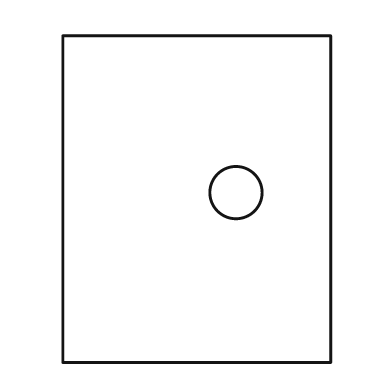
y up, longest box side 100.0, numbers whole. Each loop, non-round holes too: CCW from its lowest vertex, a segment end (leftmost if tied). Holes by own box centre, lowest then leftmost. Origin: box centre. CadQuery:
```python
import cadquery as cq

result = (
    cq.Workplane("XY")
    .moveTo(-41.0, -50.0)
    .lineTo(41.0, -50.0)
    .lineTo(41.0, 50.0)
    .lineTo(-41.0, 50.0)
    .close()
    .moveTo(12.0, 2.0)
    .circle(8.0)
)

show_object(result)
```